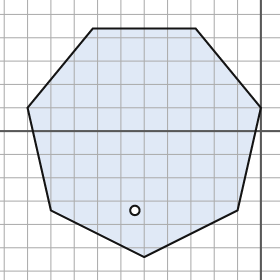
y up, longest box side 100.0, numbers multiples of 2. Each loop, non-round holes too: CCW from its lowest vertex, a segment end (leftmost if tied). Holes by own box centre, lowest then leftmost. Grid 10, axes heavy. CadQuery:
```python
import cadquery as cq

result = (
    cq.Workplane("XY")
    .moveTo(-50.0, -54.0)
    .lineTo(-10.0, -34.0)
    .lineTo(0.0, 10.0)
    .lineTo(-28.0, 44.0)
    .lineTo(-72.0, 44.0)
    .lineTo(-100.0, 10.0)
    .lineTo(-90.0, -34.0)
    .close()
    .moveTo(-54.0, -34.0)
    .circle(2.0)
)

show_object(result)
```